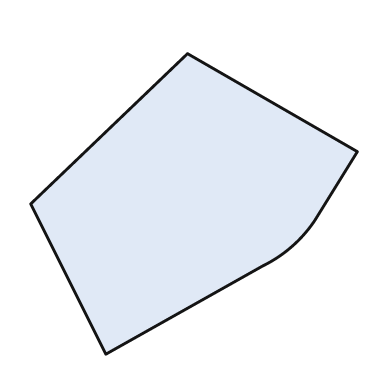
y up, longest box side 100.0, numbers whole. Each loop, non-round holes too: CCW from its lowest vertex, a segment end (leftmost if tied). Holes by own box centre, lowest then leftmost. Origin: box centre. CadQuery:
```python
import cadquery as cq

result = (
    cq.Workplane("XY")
    .moveTo(-27.0, -46.0)
    .lineTo(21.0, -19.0)
    .threePointArc((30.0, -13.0), (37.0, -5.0))
    .lineTo(50.0, 16.0)
    .lineTo(-2.0, 46.0)
    .lineTo(-50.0, 0.0)
    .close()
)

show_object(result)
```